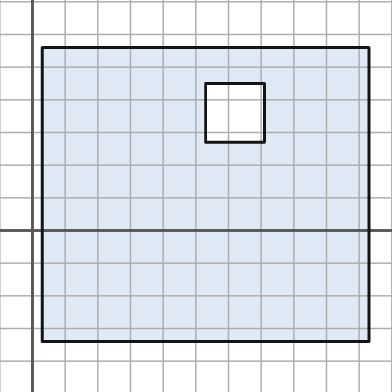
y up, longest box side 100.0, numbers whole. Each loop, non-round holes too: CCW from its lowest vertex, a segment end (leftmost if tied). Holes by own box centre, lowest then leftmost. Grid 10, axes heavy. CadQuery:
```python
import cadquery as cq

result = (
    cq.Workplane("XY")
    .moveTo(3.0, -34.0)
    .lineTo(103.0, -34.0)
    .lineTo(103.0, 56.0)
    .lineTo(3.0, 56.0)
    .close()
    .moveTo(53.0, 27.0)
    .lineTo(71.0, 27.0)
    .lineTo(71.0, 45.0)
    .lineTo(53.0, 45.0)
    .close()
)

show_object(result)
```